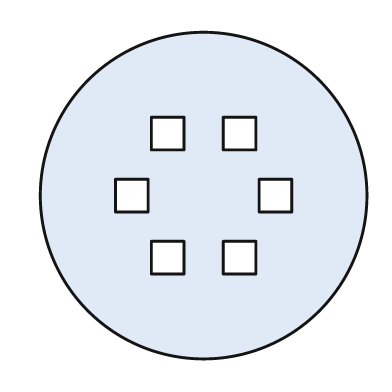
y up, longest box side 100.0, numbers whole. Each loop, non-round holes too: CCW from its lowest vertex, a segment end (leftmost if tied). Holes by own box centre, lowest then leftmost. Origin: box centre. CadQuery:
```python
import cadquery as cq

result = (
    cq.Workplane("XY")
    .moveTo(0.0, 0.0)
    .circle(50.0)
    .moveTo(-16.0, -24.0)
    .lineTo(-6.0, -24.0)
    .lineTo(-6.0, -14.0)
    .lineTo(-16.0, -14.0)
    .close()
    .moveTo(6.0, -24.0)
    .lineTo(16.0, -24.0)
    .lineTo(16.0, -14.0)
    .lineTo(6.0, -14.0)
    .close()
    .moveTo(-27.0, -5.0)
    .lineTo(-17.0, -5.0)
    .lineTo(-17.0, 5.0)
    .lineTo(-27.0, 5.0)
    .close()
    .moveTo(17.0, -5.0)
    .lineTo(27.0, -5.0)
    .lineTo(27.0, 5.0)
    .lineTo(17.0, 5.0)
    .close()
    .moveTo(-16.0, 14.0)
    .lineTo(-6.0, 14.0)
    .lineTo(-6.0, 24.0)
    .lineTo(-16.0, 24.0)
    .close()
    .moveTo(6.0, 14.0)
    .lineTo(16.0, 14.0)
    .lineTo(16.0, 24.0)
    .lineTo(6.0, 24.0)
    .close()
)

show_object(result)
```